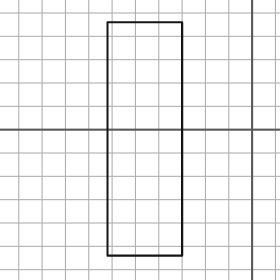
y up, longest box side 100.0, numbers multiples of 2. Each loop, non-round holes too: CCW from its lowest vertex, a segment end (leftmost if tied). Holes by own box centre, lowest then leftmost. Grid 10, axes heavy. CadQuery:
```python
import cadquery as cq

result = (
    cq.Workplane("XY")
    .moveTo(-62.0, -54.0)
    .lineTo(-30.0, -54.0)
    .lineTo(-30.0, 46.0)
    .lineTo(-62.0, 46.0)
    .close()
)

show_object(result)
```